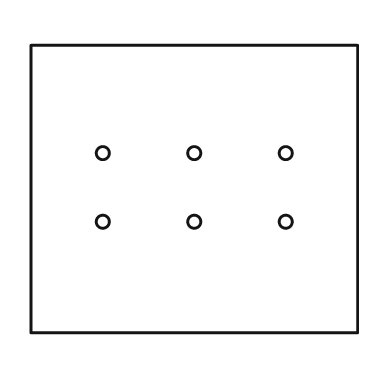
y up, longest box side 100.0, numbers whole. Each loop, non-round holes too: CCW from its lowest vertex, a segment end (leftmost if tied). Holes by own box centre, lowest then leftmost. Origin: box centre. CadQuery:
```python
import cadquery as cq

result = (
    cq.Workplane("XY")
    .moveTo(-50.0, -44.0)
    .lineTo(50.0, -44.0)
    .lineTo(50.0, 44.0)
    .lineTo(-50.0, 44.0)
    .close()
    .moveTo(-28.0, -10.0)
    .circle(2.0)
    .moveTo(0.0, -10.0)
    .circle(2.0)
    .moveTo(28.0, -10.0)
    .circle(2.0)
    .moveTo(-28.0, 11.0)
    .circle(2.0)
    .moveTo(0.0, 11.0)
    .circle(2.0)
    .moveTo(28.0, 11.0)
    .circle(2.0)
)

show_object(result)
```